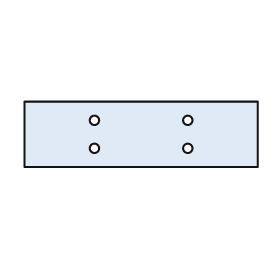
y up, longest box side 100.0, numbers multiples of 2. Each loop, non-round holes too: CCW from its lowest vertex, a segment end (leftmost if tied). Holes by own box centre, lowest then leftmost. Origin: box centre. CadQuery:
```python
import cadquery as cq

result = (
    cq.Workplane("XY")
    .moveTo(-50.0, -14.0)
    .lineTo(50.0, -14.0)
    .lineTo(50.0, 14.0)
    .lineTo(-50.0, 14.0)
    .close()
    .moveTo(-20.0, -6.0)
    .circle(2.0)
    .moveTo(20.0, -6.0)
    .circle(2.0)
    .moveTo(-20.0, 6.0)
    .circle(2.0)
    .moveTo(20.0, 6.0)
    .circle(2.0)
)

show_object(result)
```